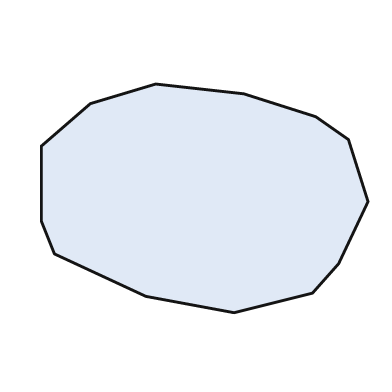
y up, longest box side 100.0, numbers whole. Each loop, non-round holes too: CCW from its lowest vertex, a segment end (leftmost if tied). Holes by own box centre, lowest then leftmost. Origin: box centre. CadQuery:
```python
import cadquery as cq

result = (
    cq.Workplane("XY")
    .moveTo(9.0, -35.0)
    .lineTo(33.0, -29.0)
    .lineTo(41.0, -20.0)
    .lineTo(50.0, -1.0)
    .lineTo(44.0, 18.0)
    .lineTo(34.0, 25.0)
    .lineTo(12.0, 32.0)
    .lineTo(-15.0, 35.0)
    .lineTo(-35.0, 29.0)
    .lineTo(-50.0, 16.0)
    .lineTo(-50.0, -7.0)
    .lineTo(-46.0, -17.0)
    .lineTo(-18.0, -30.0)
    .close()
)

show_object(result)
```